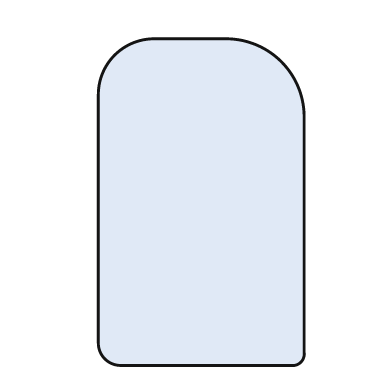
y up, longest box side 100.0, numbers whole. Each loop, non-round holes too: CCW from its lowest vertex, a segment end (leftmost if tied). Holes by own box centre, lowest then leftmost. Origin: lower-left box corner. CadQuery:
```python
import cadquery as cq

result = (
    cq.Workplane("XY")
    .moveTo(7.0, 0.0)
    .lineTo(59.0, 0.0)
    .threePointArc((62.0, 1.0), (63.0, 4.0))
    .lineTo(63.0, 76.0)
    .threePointArc((56.0, 93.0), (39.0, 100.0))
    .lineTo(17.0, 100.0)
    .threePointArc((5.0, 95.0), (0.0, 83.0))
    .lineTo(0.0, 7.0)
    .threePointArc((2.0, 2.0), (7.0, 0.0))
    .close()
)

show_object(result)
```